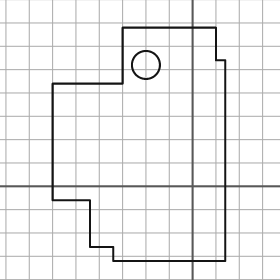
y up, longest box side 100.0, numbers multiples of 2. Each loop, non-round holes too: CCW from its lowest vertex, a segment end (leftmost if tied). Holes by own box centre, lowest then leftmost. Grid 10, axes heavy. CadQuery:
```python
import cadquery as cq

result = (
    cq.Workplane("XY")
    .moveTo(-34.0, -32.0)
    .lineTo(14.0, -32.0)
    .lineTo(14.0, 54.0)
    .lineTo(10.0, 54.0)
    .lineTo(10.0, 68.0)
    .lineTo(-30.0, 68.0)
    .lineTo(-30.0, 44.0)
    .lineTo(-60.0, 44.0)
    .lineTo(-60.0, -6.0)
    .lineTo(-44.0, -6.0)
    .lineTo(-44.0, -26.0)
    .lineTo(-34.0, -26.0)
    .close()
    .moveTo(-20.0, 52.0)
    .circle(6.0)
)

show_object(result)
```